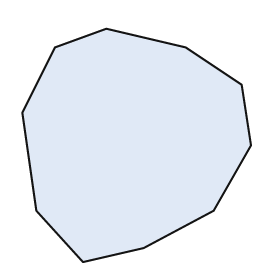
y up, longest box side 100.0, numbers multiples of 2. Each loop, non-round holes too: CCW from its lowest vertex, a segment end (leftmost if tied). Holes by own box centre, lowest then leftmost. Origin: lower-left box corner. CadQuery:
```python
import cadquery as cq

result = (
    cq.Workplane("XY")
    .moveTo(26.0, 0.0)
    .lineTo(52.0, 6.0)
    .lineTo(82.0, 22.0)
    .lineTo(98.0, 50.0)
    .lineTo(94.0, 76.0)
    .lineTo(70.0, 92.0)
    .lineTo(36.0, 100.0)
    .lineTo(14.0, 92.0)
    .lineTo(0.0, 64.0)
    .lineTo(6.0, 22.0)
    .close()
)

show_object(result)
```